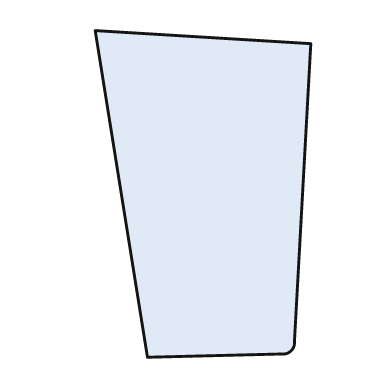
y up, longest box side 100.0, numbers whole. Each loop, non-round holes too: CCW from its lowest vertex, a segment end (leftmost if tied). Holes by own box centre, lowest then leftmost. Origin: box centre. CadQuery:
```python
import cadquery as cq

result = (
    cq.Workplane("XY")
    .moveTo(-17.0, -50.0)
    .lineTo(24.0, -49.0)
    .threePointArc((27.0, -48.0), (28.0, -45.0))
    .lineTo(33.0, 46.0)
    .lineTo(-33.0, 50.0)
    .close()
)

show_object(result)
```